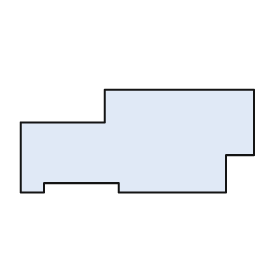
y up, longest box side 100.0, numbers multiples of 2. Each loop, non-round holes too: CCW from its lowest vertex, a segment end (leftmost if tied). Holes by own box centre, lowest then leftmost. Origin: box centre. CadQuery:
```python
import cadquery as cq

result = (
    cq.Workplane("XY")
    .moveTo(-50.0, -22.0)
    .lineTo(-40.0, -22.0)
    .lineTo(-40.0, -18.0)
    .lineTo(-8.0, -18.0)
    .lineTo(-8.0, -22.0)
    .lineTo(38.0, -22.0)
    .lineTo(38.0, -6.0)
    .lineTo(50.0, -6.0)
    .lineTo(50.0, 22.0)
    .lineTo(-14.0, 22.0)
    .lineTo(-14.0, 8.0)
    .lineTo(-50.0, 8.0)
    .close()
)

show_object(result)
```